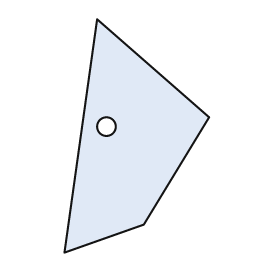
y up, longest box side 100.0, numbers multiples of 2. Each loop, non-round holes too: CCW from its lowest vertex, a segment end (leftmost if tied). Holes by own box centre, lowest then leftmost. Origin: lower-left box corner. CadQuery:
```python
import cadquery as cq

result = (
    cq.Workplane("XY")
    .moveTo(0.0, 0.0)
    .lineTo(34.0, 12.0)
    .lineTo(62.0, 58.0)
    .lineTo(14.0, 100.0)
    .close()
    .moveTo(18.0, 54.0)
    .circle(4.0)
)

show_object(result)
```